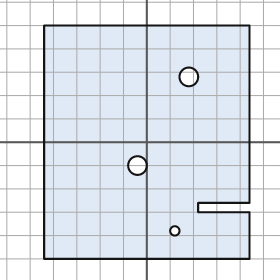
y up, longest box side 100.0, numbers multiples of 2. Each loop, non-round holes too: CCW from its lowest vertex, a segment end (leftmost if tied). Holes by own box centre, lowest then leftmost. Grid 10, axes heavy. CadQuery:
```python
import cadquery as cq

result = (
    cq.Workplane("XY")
    .moveTo(-44.0, -50.0)
    .lineTo(44.0, -50.0)
    .lineTo(44.0, -30.0)
    .lineTo(22.0, -30.0)
    .lineTo(22.0, -26.0)
    .lineTo(44.0, -26.0)
    .lineTo(44.0, 50.0)
    .lineTo(-44.0, 50.0)
    .close()
    .moveTo(12.0, -38.0)
    .circle(2.0)
    .moveTo(-4.0, -10.0)
    .circle(4.0)
    .moveTo(18.0, 28.0)
    .circle(4.0)
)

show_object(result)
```